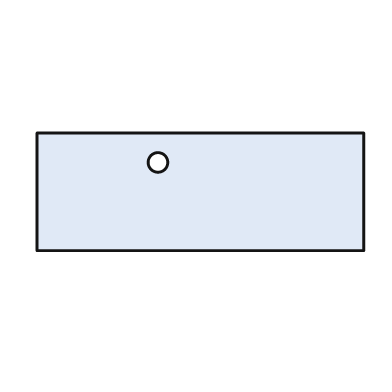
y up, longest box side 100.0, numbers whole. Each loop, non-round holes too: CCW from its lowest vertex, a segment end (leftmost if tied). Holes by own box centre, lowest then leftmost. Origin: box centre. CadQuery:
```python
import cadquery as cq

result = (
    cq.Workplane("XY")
    .moveTo(-50.0, -18.0)
    .lineTo(50.0, -18.0)
    .lineTo(50.0, 18.0)
    .lineTo(-50.0, 18.0)
    .close()
    .moveTo(-13.0, 9.0)
    .circle(3.0)
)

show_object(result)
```